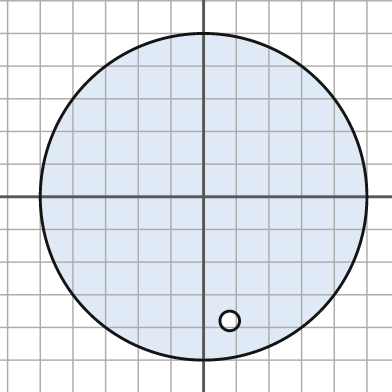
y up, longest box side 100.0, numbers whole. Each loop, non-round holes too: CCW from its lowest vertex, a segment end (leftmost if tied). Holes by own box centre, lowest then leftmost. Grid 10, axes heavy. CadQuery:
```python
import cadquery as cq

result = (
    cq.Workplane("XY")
    .moveTo(0.0, 0.0)
    .circle(50.0)
    .moveTo(8.0, -38.0)
    .circle(3.0)
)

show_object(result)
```